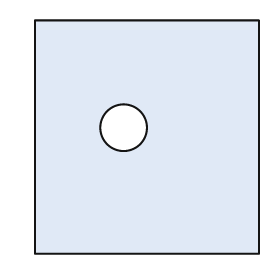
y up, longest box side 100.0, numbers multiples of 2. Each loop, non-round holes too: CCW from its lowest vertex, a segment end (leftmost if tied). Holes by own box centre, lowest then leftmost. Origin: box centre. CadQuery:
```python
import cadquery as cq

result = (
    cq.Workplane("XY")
    .moveTo(-48.0, -50.0)
    .lineTo(48.0, -50.0)
    .lineTo(48.0, 50.0)
    .lineTo(-48.0, 50.0)
    .close()
    .moveTo(-10.0, 4.0)
    .circle(10.0)
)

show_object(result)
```